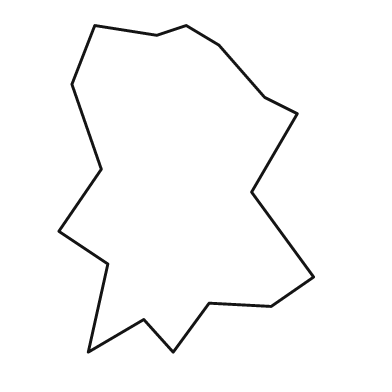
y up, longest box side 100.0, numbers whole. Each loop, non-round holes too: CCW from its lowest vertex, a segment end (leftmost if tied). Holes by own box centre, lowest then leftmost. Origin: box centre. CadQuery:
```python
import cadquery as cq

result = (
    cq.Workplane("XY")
    .moveTo(-30.0, -50.0)
    .lineTo(-13.0, -40.0)
    .lineTo(-4.0, -50.0)
    .lineTo(7.0, -35.0)
    .lineTo(26.0, -36.0)
    .lineTo(39.0, -27.0)
    .lineTo(20.0, -1.0)
    .lineTo(34.0, 23.0)
    .lineTo(24.0, 28.0)
    .lineTo(10.0, 44.0)
    .lineTo(0.0, 50.0)
    .lineTo(-9.0, 47.0)
    .lineTo(-28.0, 50.0)
    .lineTo(-35.0, 32.0)
    .lineTo(-26.0, 6.0)
    .lineTo(-39.0, -13.0)
    .lineTo(-24.0, -23.0)
    .close()
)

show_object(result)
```